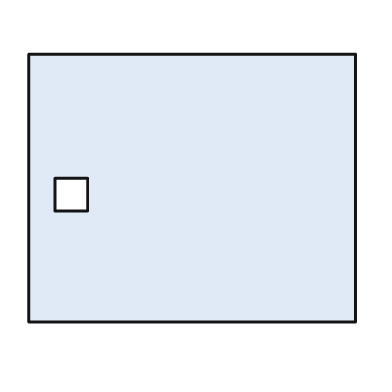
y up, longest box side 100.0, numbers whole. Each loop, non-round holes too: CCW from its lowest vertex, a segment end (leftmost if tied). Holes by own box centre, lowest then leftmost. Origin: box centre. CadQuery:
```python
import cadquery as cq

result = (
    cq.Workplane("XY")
    .moveTo(-50.0, -41.0)
    .lineTo(50.0, -41.0)
    .lineTo(50.0, 41.0)
    .lineTo(-50.0, 41.0)
    .close()
    .moveTo(-42.0, -7.0)
    .lineTo(-32.0, -7.0)
    .lineTo(-32.0, 3.0)
    .lineTo(-42.0, 3.0)
    .close()
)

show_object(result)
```